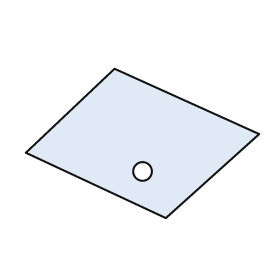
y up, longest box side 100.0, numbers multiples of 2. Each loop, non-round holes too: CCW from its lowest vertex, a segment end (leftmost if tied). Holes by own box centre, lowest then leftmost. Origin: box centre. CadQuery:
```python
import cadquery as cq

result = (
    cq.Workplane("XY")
    .moveTo(10.0, -32.0)
    .lineTo(50.0, 4.0)
    .lineTo(-12.0, 32.0)
    .lineTo(-50.0, -4.0)
    .close()
    .moveTo(0.0, -12.0)
    .circle(4.0)
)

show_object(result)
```